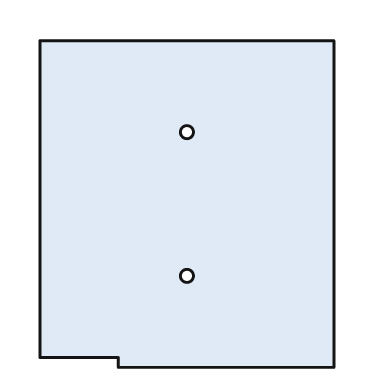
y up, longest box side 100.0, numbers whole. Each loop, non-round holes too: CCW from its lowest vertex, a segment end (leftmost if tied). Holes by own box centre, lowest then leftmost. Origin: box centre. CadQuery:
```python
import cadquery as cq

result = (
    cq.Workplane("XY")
    .moveTo(-21.0, -50.0)
    .lineTo(45.0, -50.0)
    .lineTo(45.0, 50.0)
    .lineTo(-45.0, 50.0)
    .lineTo(-45.0, -47.0)
    .lineTo(-21.0, -47.0)
    .close()
    .moveTo(0.0, -22.0)
    .circle(2.0)
    .moveTo(0.0, 22.0)
    .circle(2.0)
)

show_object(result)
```